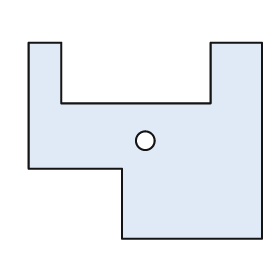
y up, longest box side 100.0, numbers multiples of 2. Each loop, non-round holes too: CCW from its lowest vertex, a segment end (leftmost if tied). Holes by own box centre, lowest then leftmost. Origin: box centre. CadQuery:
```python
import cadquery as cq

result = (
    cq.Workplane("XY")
    .moveTo(-10.0, -42.0)
    .lineTo(50.0, -42.0)
    .lineTo(50.0, 42.0)
    .lineTo(28.0, 42.0)
    .lineTo(28.0, 16.0)
    .lineTo(-36.0, 16.0)
    .lineTo(-36.0, 42.0)
    .lineTo(-50.0, 42.0)
    .lineTo(-50.0, -12.0)
    .lineTo(-10.0, -12.0)
    .close()
    .moveTo(0.0, 0.0)
    .circle(4.0)
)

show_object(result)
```